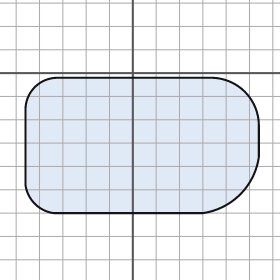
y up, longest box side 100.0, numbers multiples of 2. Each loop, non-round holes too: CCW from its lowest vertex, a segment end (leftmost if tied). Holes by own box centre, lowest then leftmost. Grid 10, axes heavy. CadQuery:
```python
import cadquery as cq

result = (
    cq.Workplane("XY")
    .moveTo(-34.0, -60.0)
    .lineTo(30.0, -60.0)
    .threePointArc((46.0, -52.0), (54.0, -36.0))
    .lineTo(54.0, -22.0)
    .threePointArc((48.0, -8.0), (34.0, -2.0))
    .lineTo(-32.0, -2.0)
    .threePointArc((-42.0, -6.0), (-46.0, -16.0))
    .lineTo(-46.0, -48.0)
    .threePointArc((-42.0, -56.0), (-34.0, -60.0))
    .close()
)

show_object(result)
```